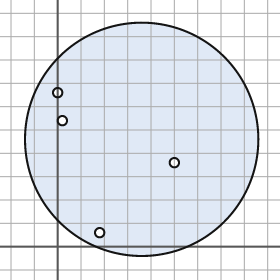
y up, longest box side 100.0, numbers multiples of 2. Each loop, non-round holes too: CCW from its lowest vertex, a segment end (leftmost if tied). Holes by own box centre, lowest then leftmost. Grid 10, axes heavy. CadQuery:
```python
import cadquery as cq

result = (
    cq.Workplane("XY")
    .moveTo(36.0, 46.0)
    .circle(50.0)
    .moveTo(18.0, 6.0)
    .circle(2.0)
    .moveTo(50.0, 36.0)
    .circle(2.0)
    .moveTo(2.0, 54.0)
    .circle(2.0)
    .moveTo(0.0, 66.0)
    .circle(2.0)
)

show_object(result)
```